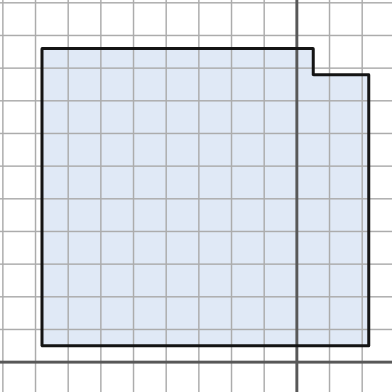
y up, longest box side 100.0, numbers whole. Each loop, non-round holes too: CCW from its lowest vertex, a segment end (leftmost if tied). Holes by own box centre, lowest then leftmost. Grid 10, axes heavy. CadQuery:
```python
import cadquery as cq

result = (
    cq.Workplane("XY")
    .moveTo(-78.0, 5.0)
    .lineTo(22.0, 5.0)
    .lineTo(22.0, 88.0)
    .lineTo(5.0, 88.0)
    .lineTo(5.0, 96.0)
    .lineTo(-78.0, 96.0)
    .close()
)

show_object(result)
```